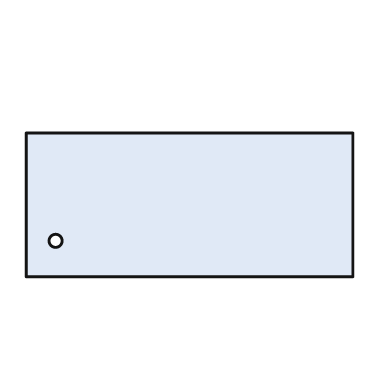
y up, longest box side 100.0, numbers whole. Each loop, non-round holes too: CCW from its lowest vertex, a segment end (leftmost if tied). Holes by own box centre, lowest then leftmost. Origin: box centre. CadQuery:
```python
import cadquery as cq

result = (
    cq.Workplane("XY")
    .moveTo(-50.0, -22.0)
    .lineTo(50.0, -22.0)
    .lineTo(50.0, 22.0)
    .lineTo(-50.0, 22.0)
    .close()
    .moveTo(-41.0, -11.0)
    .circle(2.0)
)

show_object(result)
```